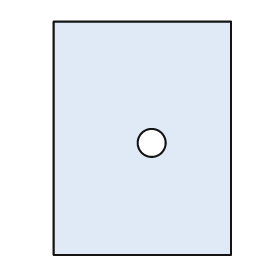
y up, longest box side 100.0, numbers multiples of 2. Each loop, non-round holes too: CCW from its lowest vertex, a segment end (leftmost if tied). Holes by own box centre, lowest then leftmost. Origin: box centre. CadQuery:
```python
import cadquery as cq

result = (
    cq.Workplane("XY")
    .moveTo(-38.0, -50.0)
    .lineTo(38.0, -50.0)
    .lineTo(38.0, 50.0)
    .lineTo(-38.0, 50.0)
    .close()
    .moveTo(4.0, -2.0)
    .circle(6.0)
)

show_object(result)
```